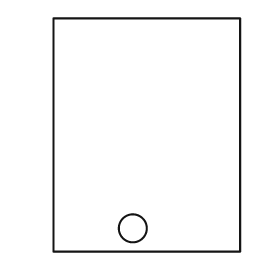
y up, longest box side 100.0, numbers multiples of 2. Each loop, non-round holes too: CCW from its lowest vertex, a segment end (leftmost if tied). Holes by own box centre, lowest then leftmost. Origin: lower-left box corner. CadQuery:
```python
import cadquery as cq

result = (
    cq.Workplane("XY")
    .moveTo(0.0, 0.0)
    .lineTo(80.0, 0.0)
    .lineTo(80.0, 100.0)
    .lineTo(0.0, 100.0)
    .close()
    .moveTo(34.0, 10.0)
    .circle(6.0)
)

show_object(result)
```